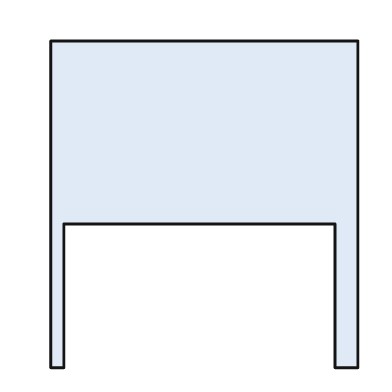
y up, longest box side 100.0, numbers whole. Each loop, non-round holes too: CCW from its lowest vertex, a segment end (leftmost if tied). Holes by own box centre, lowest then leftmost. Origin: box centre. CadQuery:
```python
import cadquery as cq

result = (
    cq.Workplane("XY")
    .moveTo(-47.0, -50.0)
    .lineTo(-43.0, -50.0)
    .lineTo(-43.0, -6.0)
    .lineTo(40.0, -6.0)
    .lineTo(40.0, -50.0)
    .lineTo(47.0, -50.0)
    .lineTo(47.0, 50.0)
    .lineTo(-47.0, 50.0)
    .close()
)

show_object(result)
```